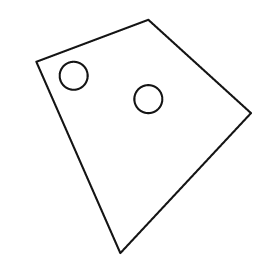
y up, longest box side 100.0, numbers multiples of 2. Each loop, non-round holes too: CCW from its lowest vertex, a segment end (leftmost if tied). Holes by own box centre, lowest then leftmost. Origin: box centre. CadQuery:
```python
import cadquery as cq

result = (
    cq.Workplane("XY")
    .moveTo(-10.0, -50.0)
    .lineTo(46.0, 10.0)
    .lineTo(2.0, 50.0)
    .lineTo(-46.0, 32.0)
    .close()
    .moveTo(2.0, 16.0)
    .circle(6.0)
    .moveTo(-30.0, 26.0)
    .circle(6.0)
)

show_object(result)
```